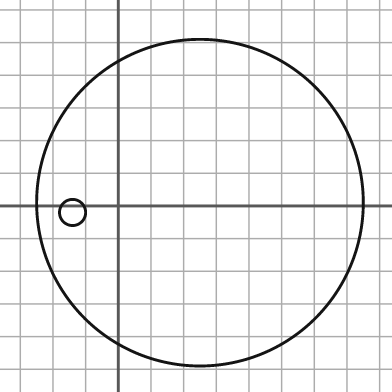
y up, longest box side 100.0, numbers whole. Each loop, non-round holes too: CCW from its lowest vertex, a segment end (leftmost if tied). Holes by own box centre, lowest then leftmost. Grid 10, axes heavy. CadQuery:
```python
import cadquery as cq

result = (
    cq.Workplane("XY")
    .moveTo(25.0, 1.0)
    .circle(50.0)
    .moveTo(-14.0, -2.0)
    .circle(4.0)
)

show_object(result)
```